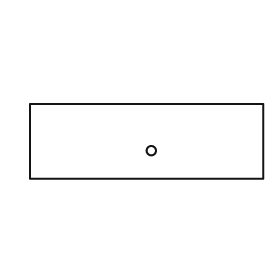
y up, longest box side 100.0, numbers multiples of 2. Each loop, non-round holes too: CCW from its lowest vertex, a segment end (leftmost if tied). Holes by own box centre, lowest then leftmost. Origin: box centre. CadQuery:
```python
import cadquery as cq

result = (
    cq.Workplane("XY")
    .moveTo(-50.0, -16.0)
    .lineTo(50.0, -16.0)
    .lineTo(50.0, 16.0)
    .lineTo(-50.0, 16.0)
    .close()
    .moveTo(2.0, -4.0)
    .circle(2.0)
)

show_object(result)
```